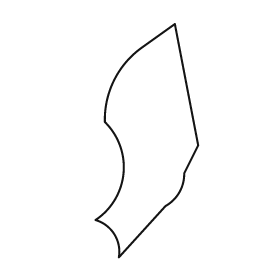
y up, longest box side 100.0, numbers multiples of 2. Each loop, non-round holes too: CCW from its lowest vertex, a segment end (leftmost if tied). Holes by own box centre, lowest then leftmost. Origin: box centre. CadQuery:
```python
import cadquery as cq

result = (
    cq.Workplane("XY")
    .moveTo(-12.0, -50.0)
    .lineTo(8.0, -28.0)
    .threePointArc((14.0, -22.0), (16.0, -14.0))
    .lineTo(22.0, -2.0)
    .lineTo(12.0, 50.0)
    .lineTo(-2.0, 40.0)
    .threePointArc((-14.0, 26.0), (-18.0, 8.0))
    .threePointArc((-10.0, -14.0), (-22.0, -34.0))
    .threePointArc((-14.0, -40.0), (-12.0, -50.0))
    .close()
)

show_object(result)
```